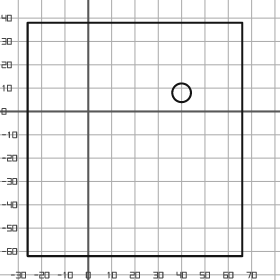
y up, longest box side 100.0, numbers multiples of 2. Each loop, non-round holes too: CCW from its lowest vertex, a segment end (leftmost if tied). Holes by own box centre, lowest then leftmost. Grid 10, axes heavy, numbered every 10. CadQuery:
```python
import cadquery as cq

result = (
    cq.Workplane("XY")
    .moveTo(-26.0, -62.0)
    .lineTo(66.0, -62.0)
    .lineTo(66.0, 38.0)
    .lineTo(-26.0, 38.0)
    .close()
    .moveTo(40.0, 8.0)
    .circle(4.0)
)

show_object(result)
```